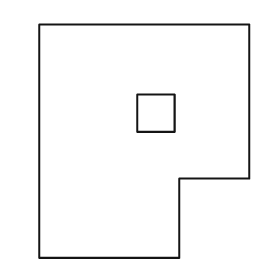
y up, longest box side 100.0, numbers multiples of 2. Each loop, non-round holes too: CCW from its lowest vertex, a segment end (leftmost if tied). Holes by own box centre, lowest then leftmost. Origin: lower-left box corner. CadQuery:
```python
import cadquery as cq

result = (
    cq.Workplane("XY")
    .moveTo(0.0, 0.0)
    .lineTo(60.0, 0.0)
    .lineTo(60.0, 34.0)
    .lineTo(90.0, 34.0)
    .lineTo(90.0, 100.0)
    .lineTo(0.0, 100.0)
    .close()
    .moveTo(42.0, 54.0)
    .lineTo(58.0, 54.0)
    .lineTo(58.0, 70.0)
    .lineTo(42.0, 70.0)
    .close()
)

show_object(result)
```